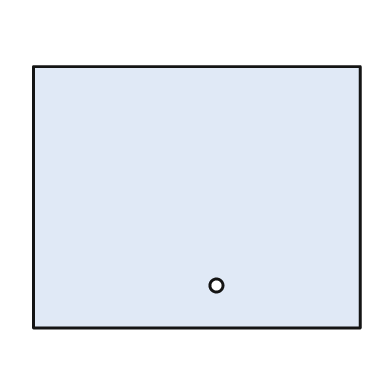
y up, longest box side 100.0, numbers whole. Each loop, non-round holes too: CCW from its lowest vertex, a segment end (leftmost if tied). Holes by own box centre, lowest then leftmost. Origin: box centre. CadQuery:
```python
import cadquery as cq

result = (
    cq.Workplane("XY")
    .moveTo(-50.0, -40.0)
    .lineTo(50.0, -40.0)
    .lineTo(50.0, 40.0)
    .lineTo(-50.0, 40.0)
    .close()
    .moveTo(6.0, -27.0)
    .circle(2.0)
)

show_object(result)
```